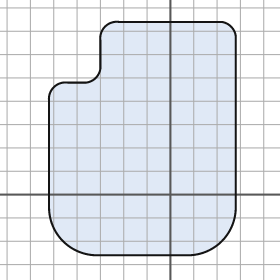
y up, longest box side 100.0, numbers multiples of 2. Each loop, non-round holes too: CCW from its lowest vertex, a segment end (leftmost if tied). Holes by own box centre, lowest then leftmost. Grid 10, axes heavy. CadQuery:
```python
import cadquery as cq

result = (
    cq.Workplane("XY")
    .moveTo(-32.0, -26.0)
    .lineTo(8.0, -26.0)
    .threePointArc((22.0, -20.0), (28.0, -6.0))
    .lineTo(28.0, 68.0)
    .threePointArc((26.0, 72.0), (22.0, 74.0))
    .lineTo(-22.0, 74.0)
    .threePointArc((-28.0, 72.0), (-30.0, 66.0))
    .lineTo(-30.0, 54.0)
    .threePointArc((-32.0, 50.0), (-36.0, 48.0))
    .lineTo(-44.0, 48.0)
    .threePointArc((-50.0, 46.0), (-52.0, 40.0))
    .lineTo(-52.0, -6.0)
    .threePointArc((-46.0, -20.0), (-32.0, -26.0))
    .close()
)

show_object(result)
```